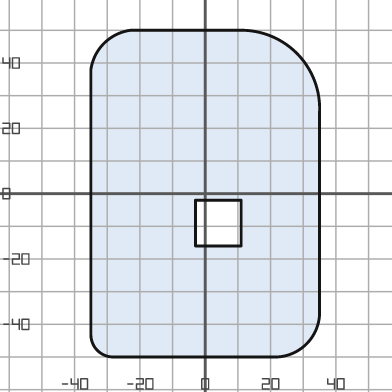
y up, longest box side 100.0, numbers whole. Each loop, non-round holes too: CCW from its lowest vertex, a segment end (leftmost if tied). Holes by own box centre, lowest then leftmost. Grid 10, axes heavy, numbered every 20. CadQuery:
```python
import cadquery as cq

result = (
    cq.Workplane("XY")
    .moveTo(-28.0, -50.0)
    .lineTo(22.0, -50.0)
    .threePointArc((31.0, -46.0), (35.0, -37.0))
    .lineTo(35.0, 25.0)
    .threePointArc((28.0, 43.0), (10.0, 50.0))
    .lineTo(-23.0, 50.0)
    .threePointArc((-31.0, 46.0), (-35.0, 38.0))
    .lineTo(-35.0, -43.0)
    .threePointArc((-33.0, -48.0), (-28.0, -50.0))
    .close()
    .moveTo(-3.0, -16.0)
    .lineTo(11.0, -16.0)
    .lineTo(11.0, -2.0)
    .lineTo(-3.0, -2.0)
    .close()
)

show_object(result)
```